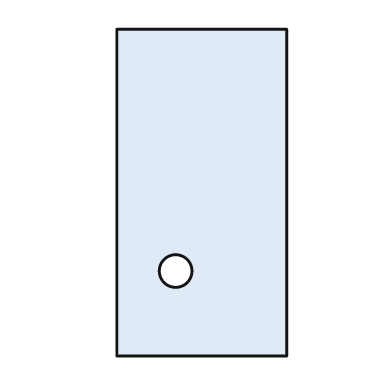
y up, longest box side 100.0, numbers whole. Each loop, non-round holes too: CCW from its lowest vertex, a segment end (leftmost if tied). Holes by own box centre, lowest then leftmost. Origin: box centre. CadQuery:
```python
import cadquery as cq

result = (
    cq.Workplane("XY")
    .moveTo(-26.0, -50.0)
    .lineTo(26.0, -50.0)
    .lineTo(26.0, 50.0)
    .lineTo(-26.0, 50.0)
    .close()
    .moveTo(-8.0, -24.0)
    .circle(5.0)
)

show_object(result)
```